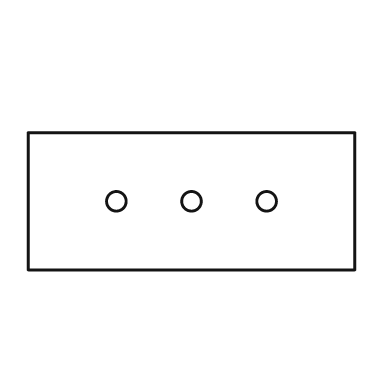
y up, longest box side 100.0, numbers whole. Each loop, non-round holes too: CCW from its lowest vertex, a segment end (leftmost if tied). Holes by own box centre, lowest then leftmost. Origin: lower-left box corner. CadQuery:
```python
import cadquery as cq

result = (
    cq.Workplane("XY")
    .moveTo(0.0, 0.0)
    .lineTo(100.0, 0.0)
    .lineTo(100.0, 42.0)
    .lineTo(0.0, 42.0)
    .close()
    .moveTo(27.0, 21.0)
    .circle(3.0)
    .moveTo(50.0, 21.0)
    .circle(3.0)
    .moveTo(73.0, 21.0)
    .circle(3.0)
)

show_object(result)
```